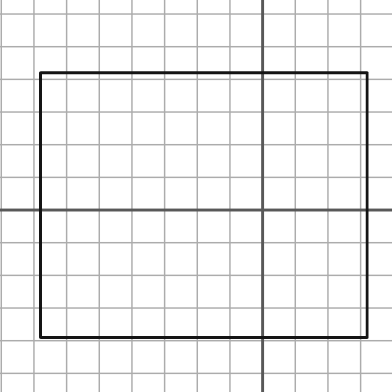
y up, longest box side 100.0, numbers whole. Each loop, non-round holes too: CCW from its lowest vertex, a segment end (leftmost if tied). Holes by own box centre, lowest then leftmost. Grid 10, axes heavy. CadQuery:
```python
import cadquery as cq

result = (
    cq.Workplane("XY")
    .moveTo(-68.0, -39.0)
    .lineTo(32.0, -39.0)
    .lineTo(32.0, 42.0)
    .lineTo(-68.0, 42.0)
    .close()
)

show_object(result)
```